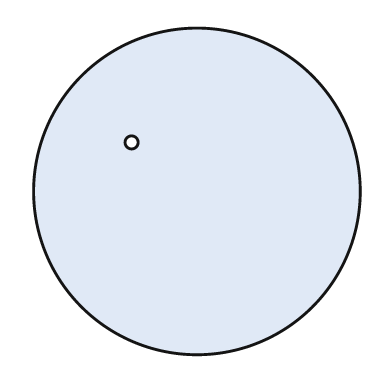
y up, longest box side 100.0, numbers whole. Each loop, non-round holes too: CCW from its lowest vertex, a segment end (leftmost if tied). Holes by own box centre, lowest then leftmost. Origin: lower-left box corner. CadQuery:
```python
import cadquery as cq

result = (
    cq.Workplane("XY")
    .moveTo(50.0, 50.0)
    .circle(50.0)
    .moveTo(30.0, 65.0)
    .circle(2.0)
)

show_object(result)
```